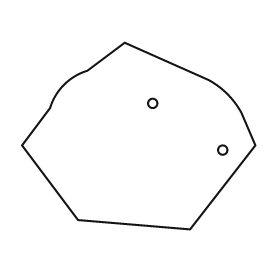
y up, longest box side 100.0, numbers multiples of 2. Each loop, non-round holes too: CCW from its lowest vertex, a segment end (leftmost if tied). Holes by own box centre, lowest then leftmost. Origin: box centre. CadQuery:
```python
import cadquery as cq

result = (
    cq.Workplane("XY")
    .moveTo(22.0, -40.0)
    .lineTo(50.0, -4.0)
    .lineTo(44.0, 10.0)
    .threePointArc((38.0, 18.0), (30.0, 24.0))
    .lineTo(-6.0, 40.0)
    .lineTo(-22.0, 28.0)
    .threePointArc((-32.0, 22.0), (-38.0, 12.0))
    .lineTo(-50.0, -4.0)
    .lineTo(-26.0, -36.0)
    .close()
    .moveTo(36.0, -6.0)
    .circle(2.0)
    .moveTo(6.0, 14.0)
    .circle(2.0)
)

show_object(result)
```